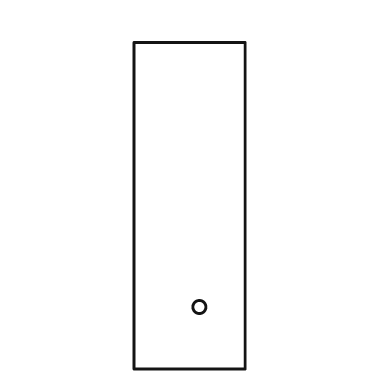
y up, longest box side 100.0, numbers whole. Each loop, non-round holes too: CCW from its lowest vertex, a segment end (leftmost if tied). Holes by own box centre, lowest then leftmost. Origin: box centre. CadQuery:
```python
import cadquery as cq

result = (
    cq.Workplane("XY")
    .moveTo(-17.0, -50.0)
    .lineTo(17.0, -50.0)
    .lineTo(17.0, 50.0)
    .lineTo(-17.0, 50.0)
    .close()
    .moveTo(3.0, -31.0)
    .circle(2.0)
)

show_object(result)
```